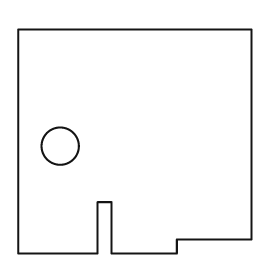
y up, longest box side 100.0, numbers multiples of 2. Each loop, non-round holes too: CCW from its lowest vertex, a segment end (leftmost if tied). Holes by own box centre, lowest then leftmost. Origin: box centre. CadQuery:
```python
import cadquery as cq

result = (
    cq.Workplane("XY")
    .moveTo(-50.0, -48.0)
    .lineTo(-16.0, -48.0)
    .lineTo(-16.0, -26.0)
    .lineTo(-10.0, -26.0)
    .lineTo(-10.0, -48.0)
    .lineTo(18.0, -48.0)
    .lineTo(18.0, -42.0)
    .lineTo(50.0, -42.0)
    .lineTo(50.0, 48.0)
    .lineTo(-50.0, 48.0)
    .close()
    .moveTo(-32.0, -2.0)
    .circle(8.0)
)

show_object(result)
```